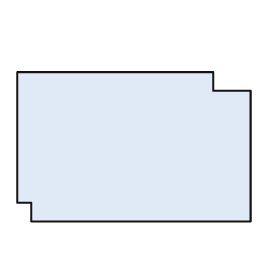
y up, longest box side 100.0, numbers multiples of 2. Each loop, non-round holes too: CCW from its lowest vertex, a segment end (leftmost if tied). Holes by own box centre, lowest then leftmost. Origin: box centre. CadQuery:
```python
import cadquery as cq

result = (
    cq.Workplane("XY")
    .moveTo(-44.0, -32.0)
    .lineTo(50.0, -32.0)
    .lineTo(50.0, 24.0)
    .lineTo(34.0, 24.0)
    .lineTo(34.0, 32.0)
    .lineTo(-50.0, 32.0)
    .lineTo(-50.0, -24.0)
    .lineTo(-44.0, -24.0)
    .close()
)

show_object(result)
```